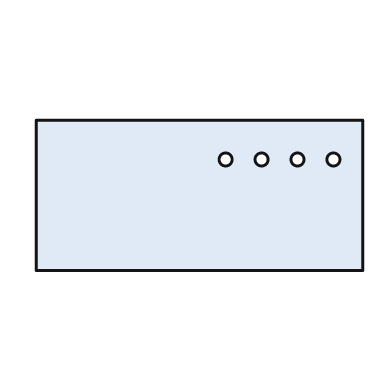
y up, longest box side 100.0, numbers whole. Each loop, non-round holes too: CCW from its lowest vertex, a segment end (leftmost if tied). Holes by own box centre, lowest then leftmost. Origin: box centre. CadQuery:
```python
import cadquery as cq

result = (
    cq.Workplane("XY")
    .moveTo(-50.0, -23.0)
    .lineTo(50.0, -23.0)
    .lineTo(50.0, 23.0)
    .lineTo(-50.0, 23.0)
    .close()
    .moveTo(8.0, 11.0)
    .circle(2.0)
    .moveTo(19.0, 11.0)
    .circle(2.0)
    .moveTo(30.0, 11.0)
    .circle(2.0)
    .moveTo(41.0, 11.0)
    .circle(2.0)
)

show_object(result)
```